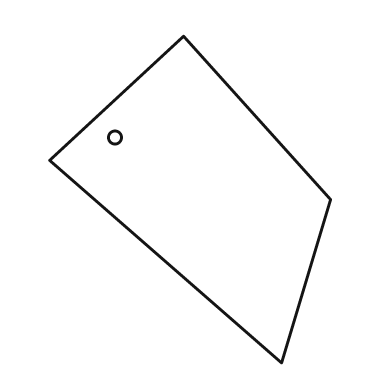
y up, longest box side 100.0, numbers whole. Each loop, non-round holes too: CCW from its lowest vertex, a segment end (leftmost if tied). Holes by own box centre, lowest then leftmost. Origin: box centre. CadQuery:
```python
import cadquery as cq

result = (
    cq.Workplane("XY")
    .moveTo(28.0, -50.0)
    .lineTo(43.0, 0.0)
    .lineTo(-2.0, 50.0)
    .lineTo(-43.0, 12.0)
    .close()
    .moveTo(-23.0, 19.0)
    .circle(2.0)
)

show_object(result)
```